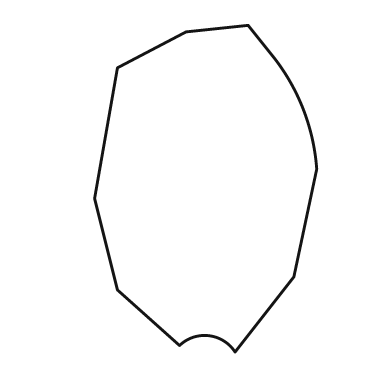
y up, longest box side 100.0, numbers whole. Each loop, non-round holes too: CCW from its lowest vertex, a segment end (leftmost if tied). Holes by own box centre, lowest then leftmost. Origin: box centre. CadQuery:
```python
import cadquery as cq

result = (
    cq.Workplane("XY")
    .moveTo(9.0, -50.0)
    .lineTo(27.0, -27.0)
    .lineTo(34.0, 6.0)
    .threePointArc((30.0, 24.0), (21.0, 40.0))
    .lineTo(13.0, 50.0)
    .lineTo(-6.0, 48.0)
    .lineTo(-27.0, 37.0)
    .lineTo(-34.0, -3.0)
    .lineTo(-27.0, -31.0)
    .lineTo(-8.0, -48.0)
    .threePointArc((1.0, -45.0), (9.0, -50.0))
    .close()
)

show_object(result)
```